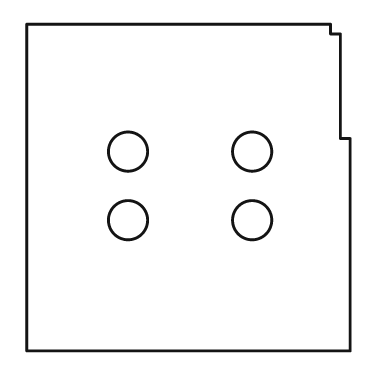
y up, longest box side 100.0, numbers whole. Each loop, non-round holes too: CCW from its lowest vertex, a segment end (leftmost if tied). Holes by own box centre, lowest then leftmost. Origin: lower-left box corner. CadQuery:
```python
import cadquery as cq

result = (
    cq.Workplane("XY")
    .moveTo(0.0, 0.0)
    .lineTo(99.0, 0.0)
    .lineTo(99.0, 65.0)
    .lineTo(96.0, 65.0)
    .lineTo(96.0, 97.0)
    .lineTo(93.0, 97.0)
    .lineTo(93.0, 100.0)
    .lineTo(0.0, 100.0)
    .close()
    .moveTo(31.0, 40.0)
    .circle(6.0)
    .moveTo(69.0, 40.0)
    .circle(6.0)
    .moveTo(31.0, 61.0)
    .circle(6.0)
    .moveTo(69.0, 61.0)
    .circle(6.0)
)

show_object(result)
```